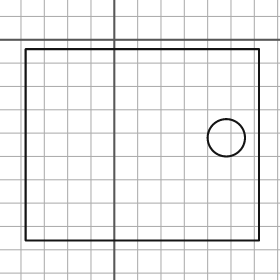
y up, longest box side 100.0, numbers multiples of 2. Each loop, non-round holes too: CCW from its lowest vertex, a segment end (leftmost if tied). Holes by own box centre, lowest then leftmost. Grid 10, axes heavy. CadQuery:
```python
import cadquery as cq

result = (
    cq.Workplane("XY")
    .moveTo(-38.0, -86.0)
    .lineTo(62.0, -86.0)
    .lineTo(62.0, -4.0)
    .lineTo(-38.0, -4.0)
    .close()
    .moveTo(48.0, -42.0)
    .circle(8.0)
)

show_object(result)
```